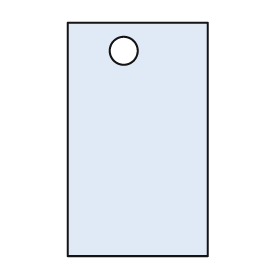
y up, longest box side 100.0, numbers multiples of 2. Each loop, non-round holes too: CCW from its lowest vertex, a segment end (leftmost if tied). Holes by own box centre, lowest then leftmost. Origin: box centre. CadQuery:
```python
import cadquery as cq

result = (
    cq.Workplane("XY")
    .moveTo(-30.0, -50.0)
    .lineTo(30.0, -50.0)
    .lineTo(30.0, 50.0)
    .lineTo(-30.0, 50.0)
    .close()
    .moveTo(-6.0, 38.0)
    .circle(6.0)
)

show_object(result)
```